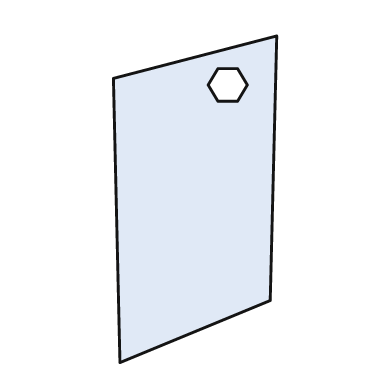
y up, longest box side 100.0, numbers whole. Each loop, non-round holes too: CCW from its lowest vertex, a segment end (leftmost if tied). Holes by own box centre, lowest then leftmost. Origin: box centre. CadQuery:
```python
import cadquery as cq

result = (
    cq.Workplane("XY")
    .moveTo(-23.0, -50.0)
    .lineTo(23.0, -31.0)
    .lineTo(25.0, 50.0)
    .lineTo(-25.0, 37.0)
    .close()
    .moveTo(7.0, 30.0)
    .lineTo(13.0, 30.0)
    .lineTo(16.0, 35.0)
    .lineTo(13.0, 40.0)
    .lineTo(7.0, 40.0)
    .lineTo(4.0, 35.0)
    .close()
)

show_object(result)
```